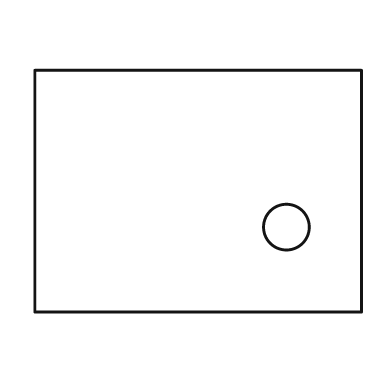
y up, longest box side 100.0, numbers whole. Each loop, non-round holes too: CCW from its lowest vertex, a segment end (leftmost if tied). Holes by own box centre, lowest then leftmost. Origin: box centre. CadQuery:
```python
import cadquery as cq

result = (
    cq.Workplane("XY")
    .moveTo(-50.0, -37.0)
    .lineTo(50.0, -37.0)
    .lineTo(50.0, 37.0)
    .lineTo(-50.0, 37.0)
    .close()
    .moveTo(27.0, -11.0)
    .circle(7.0)
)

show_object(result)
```